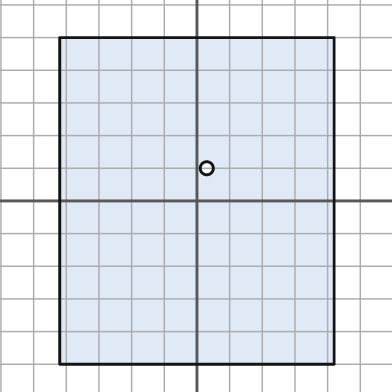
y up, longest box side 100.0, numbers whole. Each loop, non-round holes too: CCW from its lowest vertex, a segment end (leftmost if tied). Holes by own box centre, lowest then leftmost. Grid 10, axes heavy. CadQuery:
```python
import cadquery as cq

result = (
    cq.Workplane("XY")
    .moveTo(-42.0, -50.0)
    .lineTo(42.0, -50.0)
    .lineTo(42.0, 50.0)
    .lineTo(-42.0, 50.0)
    .close()
    .moveTo(3.0, 10.0)
    .circle(2.0)
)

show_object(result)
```